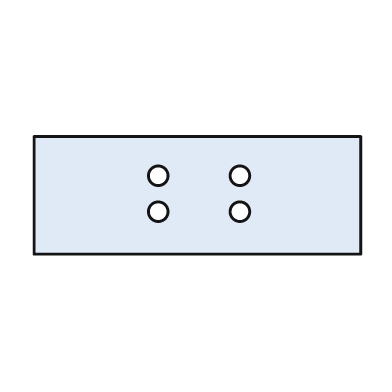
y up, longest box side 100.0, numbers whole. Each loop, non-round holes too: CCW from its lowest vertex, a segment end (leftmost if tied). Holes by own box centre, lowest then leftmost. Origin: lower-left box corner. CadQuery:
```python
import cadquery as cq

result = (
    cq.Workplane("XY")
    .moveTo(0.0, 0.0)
    .lineTo(100.0, 0.0)
    .lineTo(100.0, 36.0)
    .lineTo(0.0, 36.0)
    .close()
    .moveTo(38.0, 13.0)
    .circle(3.0)
    .moveTo(63.0, 13.0)
    .circle(3.0)
    .moveTo(38.0, 24.0)
    .circle(3.0)
    .moveTo(63.0, 24.0)
    .circle(3.0)
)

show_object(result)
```